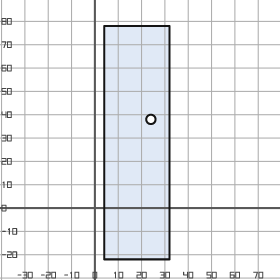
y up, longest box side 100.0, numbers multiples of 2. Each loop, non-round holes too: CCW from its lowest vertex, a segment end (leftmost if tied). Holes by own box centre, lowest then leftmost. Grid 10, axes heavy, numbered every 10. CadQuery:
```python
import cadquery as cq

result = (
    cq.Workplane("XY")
    .moveTo(4.0, -22.0)
    .lineTo(32.0, -22.0)
    .lineTo(32.0, 78.0)
    .lineTo(4.0, 78.0)
    .close()
    .moveTo(24.0, 38.0)
    .circle(2.0)
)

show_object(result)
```